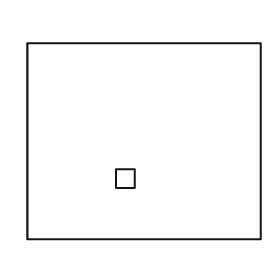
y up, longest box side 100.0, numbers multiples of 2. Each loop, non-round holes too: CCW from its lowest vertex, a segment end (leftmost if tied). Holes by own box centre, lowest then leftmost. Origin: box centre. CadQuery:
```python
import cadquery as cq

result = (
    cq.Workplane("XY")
    .moveTo(-50.0, -42.0)
    .lineTo(50.0, -42.0)
    .lineTo(50.0, 42.0)
    .lineTo(-50.0, 42.0)
    .close()
    .moveTo(-12.0, -20.0)
    .lineTo(-4.0, -20.0)
    .lineTo(-4.0, -12.0)
    .lineTo(-12.0, -12.0)
    .close()
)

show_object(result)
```